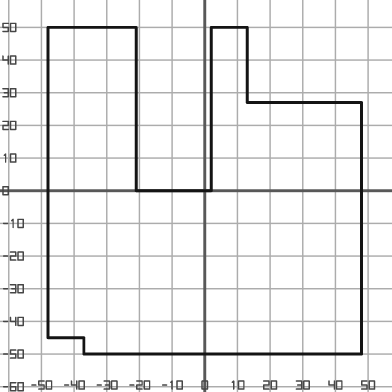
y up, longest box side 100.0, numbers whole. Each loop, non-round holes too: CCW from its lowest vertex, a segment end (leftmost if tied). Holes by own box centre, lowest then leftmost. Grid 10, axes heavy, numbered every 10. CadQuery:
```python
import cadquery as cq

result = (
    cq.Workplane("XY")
    .moveTo(-37.0, -50.0)
    .lineTo(48.0, -50.0)
    .lineTo(48.0, 27.0)
    .lineTo(13.0, 27.0)
    .lineTo(13.0, 50.0)
    .lineTo(2.0, 50.0)
    .lineTo(2.0, 0.0)
    .lineTo(-21.0, 0.0)
    .lineTo(-21.0, 50.0)
    .lineTo(-48.0, 50.0)
    .lineTo(-48.0, -45.0)
    .lineTo(-37.0, -45.0)
    .close()
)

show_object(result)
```